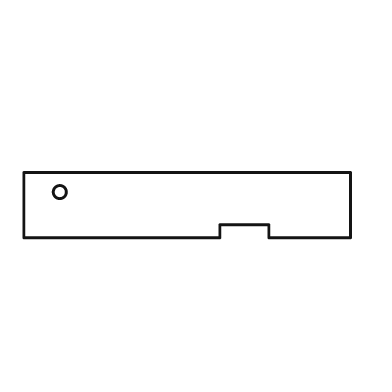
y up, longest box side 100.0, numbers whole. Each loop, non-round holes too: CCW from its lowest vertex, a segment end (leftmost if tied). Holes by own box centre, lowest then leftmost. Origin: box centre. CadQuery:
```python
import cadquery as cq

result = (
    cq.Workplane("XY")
    .moveTo(-50.0, -10.0)
    .lineTo(10.0, -10.0)
    .lineTo(10.0, -6.0)
    .lineTo(25.0, -6.0)
    .lineTo(25.0, -10.0)
    .lineTo(50.0, -10.0)
    .lineTo(50.0, 10.0)
    .lineTo(-50.0, 10.0)
    .close()
    .moveTo(-39.0, 4.0)
    .circle(2.0)
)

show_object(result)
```